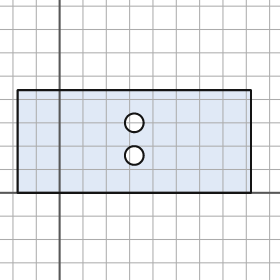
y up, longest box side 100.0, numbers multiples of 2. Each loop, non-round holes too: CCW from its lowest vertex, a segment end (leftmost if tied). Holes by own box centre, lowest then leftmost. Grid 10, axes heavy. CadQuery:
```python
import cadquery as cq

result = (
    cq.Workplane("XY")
    .moveTo(-18.0, 0.0)
    .lineTo(82.0, 0.0)
    .lineTo(82.0, 44.0)
    .lineTo(-18.0, 44.0)
    .close()
    .moveTo(32.0, 16.0)
    .circle(4.0)
    .moveTo(32.0, 30.0)
    .circle(4.0)
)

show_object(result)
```